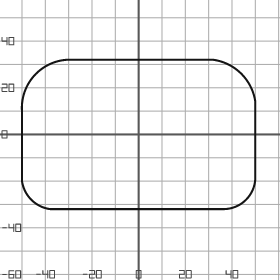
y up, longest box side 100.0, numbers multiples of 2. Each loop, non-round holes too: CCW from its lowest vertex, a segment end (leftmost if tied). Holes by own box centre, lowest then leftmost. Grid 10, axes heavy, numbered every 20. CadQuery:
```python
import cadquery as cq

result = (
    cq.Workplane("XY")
    .moveTo(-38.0, -32.0)
    .lineTo(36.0, -32.0)
    .threePointArc((46.0, -28.0), (50.0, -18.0))
    .lineTo(50.0, 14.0)
    .threePointArc((44.0, 26.0), (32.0, 32.0))
    .lineTo(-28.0, 32.0)
    .threePointArc((-44.0, 26.0), (-50.0, 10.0))
    .lineTo(-50.0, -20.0)
    .threePointArc((-46.0, -28.0), (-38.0, -32.0))
    .close()
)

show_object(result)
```